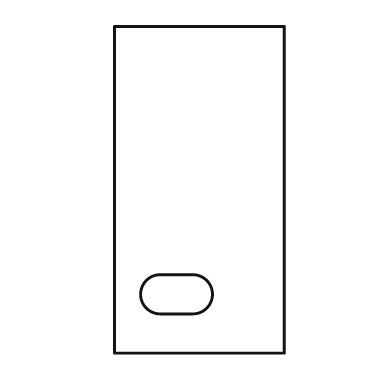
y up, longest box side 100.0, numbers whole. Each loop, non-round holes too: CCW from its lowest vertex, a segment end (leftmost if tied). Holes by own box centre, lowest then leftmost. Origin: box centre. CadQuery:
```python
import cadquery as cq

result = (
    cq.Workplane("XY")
    .moveTo(-26.0, -50.0)
    .lineTo(26.0, -50.0)
    .lineTo(26.0, 50.0)
    .lineTo(-26.0, 50.0)
    .close()
    .moveTo(-12.0, -38.0)
    .lineTo(-2.0, -38.0)
    .threePointArc((4.0, -32.0), (-2.0, -26.0))
    .lineTo(-12.0, -26.0)
    .threePointArc((-18.0, -32.0), (-12.0, -38.0))
    .close()
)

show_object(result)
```